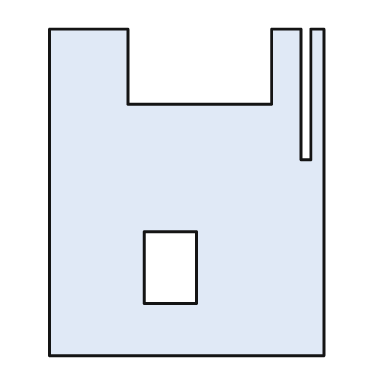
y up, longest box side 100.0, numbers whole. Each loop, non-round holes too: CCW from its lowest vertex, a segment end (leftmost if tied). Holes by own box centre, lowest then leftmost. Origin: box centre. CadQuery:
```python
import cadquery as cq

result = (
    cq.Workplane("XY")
    .moveTo(-42.0, -50.0)
    .lineTo(42.0, -50.0)
    .lineTo(42.0, 50.0)
    .lineTo(38.0, 50.0)
    .lineTo(38.0, 10.0)
    .lineTo(35.0, 10.0)
    .lineTo(35.0, 50.0)
    .lineTo(26.0, 50.0)
    .lineTo(26.0, 27.0)
    .lineTo(-18.0, 27.0)
    .lineTo(-18.0, 50.0)
    .lineTo(-42.0, 50.0)
    .close()
    .moveTo(-13.0, -34.0)
    .lineTo(3.0, -34.0)
    .lineTo(3.0, -12.0)
    .lineTo(-13.0, -12.0)
    .close()
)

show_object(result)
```